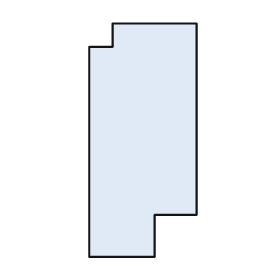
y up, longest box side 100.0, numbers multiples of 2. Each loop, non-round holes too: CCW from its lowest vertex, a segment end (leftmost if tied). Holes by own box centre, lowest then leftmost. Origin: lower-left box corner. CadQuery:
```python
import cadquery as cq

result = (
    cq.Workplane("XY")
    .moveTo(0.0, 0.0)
    .lineTo(28.0, 0.0)
    .lineTo(28.0, 18.0)
    .lineTo(46.0, 18.0)
    .lineTo(46.0, 100.0)
    .lineTo(10.0, 100.0)
    .lineTo(10.0, 90.0)
    .lineTo(0.0, 90.0)
    .close()
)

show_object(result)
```